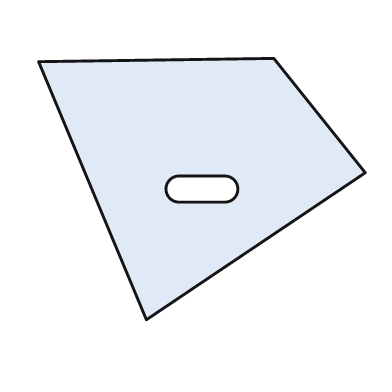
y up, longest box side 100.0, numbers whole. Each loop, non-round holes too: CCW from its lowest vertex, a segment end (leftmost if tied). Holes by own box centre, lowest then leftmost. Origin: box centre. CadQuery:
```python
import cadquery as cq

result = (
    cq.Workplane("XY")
    .moveTo(-17.0, -40.0)
    .lineTo(50.0, 5.0)
    .lineTo(22.0, 40.0)
    .lineTo(-50.0, 39.0)
    .close()
    .moveTo(-7.0, -4.0)
    .lineTo(7.0, -4.0)
    .threePointArc((11.0, 0.0), (7.0, 4.0))
    .lineTo(-7.0, 4.0)
    .threePointArc((-11.0, 0.0), (-7.0, -4.0))
    .close()
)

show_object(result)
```